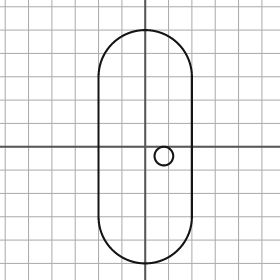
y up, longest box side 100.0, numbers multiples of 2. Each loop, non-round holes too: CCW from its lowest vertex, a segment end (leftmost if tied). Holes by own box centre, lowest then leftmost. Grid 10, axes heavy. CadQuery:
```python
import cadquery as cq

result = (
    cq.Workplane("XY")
    .moveTo(-20.0, -30.0)
    .threePointArc((0.0, -50.0), (20.0, -30.0))
    .lineTo(20.0, 30.0)
    .threePointArc((0.0, 50.0), (-20.0, 30.0))
    .close()
    .moveTo(8.0, -4.0)
    .circle(4.0)
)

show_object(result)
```